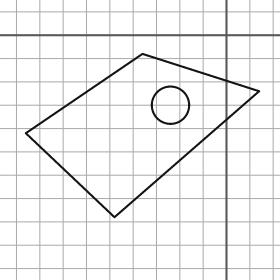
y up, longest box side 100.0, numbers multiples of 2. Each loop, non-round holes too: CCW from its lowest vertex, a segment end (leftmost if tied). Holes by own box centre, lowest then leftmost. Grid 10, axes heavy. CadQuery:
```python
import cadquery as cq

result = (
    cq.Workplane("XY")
    .moveTo(-48.0, -78.0)
    .lineTo(14.0, -24.0)
    .lineTo(-36.0, -8.0)
    .lineTo(-86.0, -42.0)
    .close()
    .moveTo(-24.0, -30.0)
    .circle(8.0)
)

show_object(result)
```